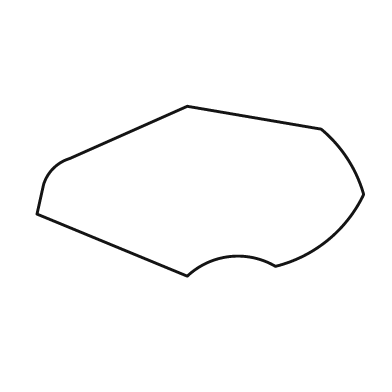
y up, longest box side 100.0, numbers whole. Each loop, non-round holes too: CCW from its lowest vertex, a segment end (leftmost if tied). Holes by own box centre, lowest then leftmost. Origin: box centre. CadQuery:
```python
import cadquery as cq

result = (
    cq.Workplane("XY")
    .moveTo(-4.0, -26.0)
    .threePointArc((9.0, -20.0), (23.0, -23.0))
    .threePointArc((39.0, -15.0), (50.0, -1.0))
    .threePointArc((45.0, 10.0), (37.0, 19.0))
    .lineTo(-4.0, 26.0)
    .lineTo(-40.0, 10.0)
    .threePointArc((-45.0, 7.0), (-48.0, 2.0))
    .lineTo(-50.0, -7.0)
    .close()
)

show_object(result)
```